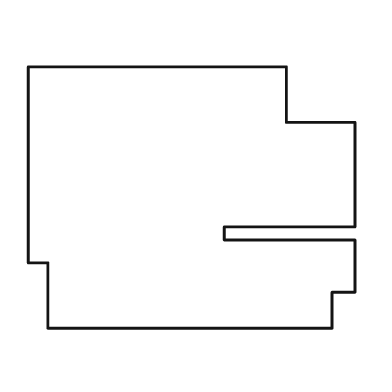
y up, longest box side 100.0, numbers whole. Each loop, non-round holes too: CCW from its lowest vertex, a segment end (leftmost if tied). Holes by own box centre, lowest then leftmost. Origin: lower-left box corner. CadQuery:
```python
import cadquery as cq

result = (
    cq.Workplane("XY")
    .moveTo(6.0, 0.0)
    .lineTo(93.0, 0.0)
    .lineTo(93.0, 11.0)
    .lineTo(100.0, 11.0)
    .lineTo(100.0, 27.0)
    .lineTo(60.0, 27.0)
    .lineTo(60.0, 31.0)
    .lineTo(100.0, 31.0)
    .lineTo(100.0, 63.0)
    .lineTo(79.0, 63.0)
    .lineTo(79.0, 80.0)
    .lineTo(0.0, 80.0)
    .lineTo(0.0, 20.0)
    .lineTo(6.0, 20.0)
    .close()
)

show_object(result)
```